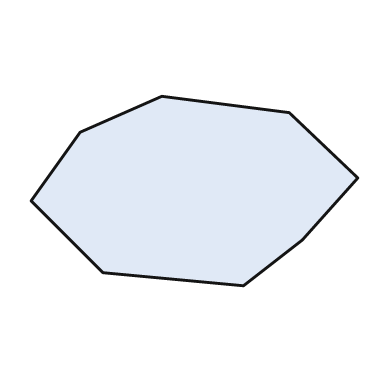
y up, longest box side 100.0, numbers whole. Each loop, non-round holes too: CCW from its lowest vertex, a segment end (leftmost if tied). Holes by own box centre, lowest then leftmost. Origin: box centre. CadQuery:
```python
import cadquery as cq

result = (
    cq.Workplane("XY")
    .moveTo(15.0, -29.0)
    .lineTo(33.0, -15.0)
    .lineTo(50.0, 4.0)
    .lineTo(29.0, 24.0)
    .lineTo(-10.0, 29.0)
    .lineTo(-35.0, 18.0)
    .lineTo(-50.0, -3.0)
    .lineTo(-28.0, -25.0)
    .close()
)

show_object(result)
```